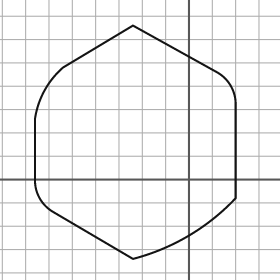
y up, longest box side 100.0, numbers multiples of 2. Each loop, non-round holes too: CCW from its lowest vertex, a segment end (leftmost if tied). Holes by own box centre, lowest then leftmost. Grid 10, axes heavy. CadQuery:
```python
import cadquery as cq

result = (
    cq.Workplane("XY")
    .moveTo(-24.0, -34.0)
    .threePointArc((0.0, -24.0), (20.0, -8.0))
    .lineTo(20.0, 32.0)
    .threePointArc((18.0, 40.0), (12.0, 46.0))
    .lineTo(-24.0, 66.0)
    .lineTo(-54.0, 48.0)
    .threePointArc((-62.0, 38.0), (-66.0, 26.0))
    .lineTo(-66.0, 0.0)
    .threePointArc((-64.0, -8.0), (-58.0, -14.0))
    .close()
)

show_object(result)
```